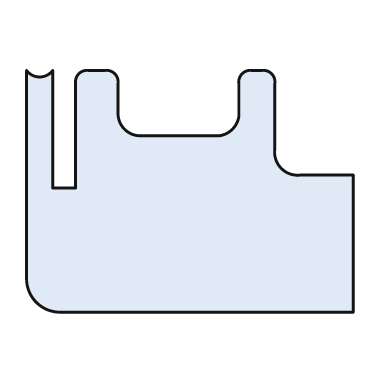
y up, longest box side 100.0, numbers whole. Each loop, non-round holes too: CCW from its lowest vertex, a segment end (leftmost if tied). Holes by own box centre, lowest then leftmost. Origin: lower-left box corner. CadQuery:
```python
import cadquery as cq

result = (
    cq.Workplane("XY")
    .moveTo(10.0, 0.0)
    .lineTo(100.0, 0.0)
    .lineTo(100.0, 42.0)
    .lineTo(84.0, 42.0)
    .threePointArc((78.0, 44.0), (76.0, 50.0))
    .lineTo(76.0, 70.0)
    .threePointArc((75.0, 73.0), (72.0, 74.0))
    .lineTo(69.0, 74.0)
    .threePointArc((66.0, 73.0), (65.0, 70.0))
    .lineTo(65.0, 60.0)
    .threePointArc((63.0, 56.0), (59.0, 54.0))
    .lineTo(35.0, 54.0)
    .threePointArc((30.0, 56.0), (28.0, 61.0))
    .lineTo(28.0, 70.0)
    .threePointArc((27.0, 73.0), (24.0, 74.0))
    .lineTo(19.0, 74.0)
    .threePointArc((16.0, 73.0), (15.0, 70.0))
    .lineTo(15.0, 38.0)
    .lineTo(8.0, 38.0)
    .lineTo(8.0, 74.0)
    .threePointArc((4.0, 72.0), (0.0, 74.0))
    .lineTo(0.0, 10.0)
    .threePointArc((3.0, 3.0), (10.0, 0.0))
    .close()
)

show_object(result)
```